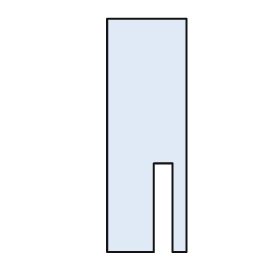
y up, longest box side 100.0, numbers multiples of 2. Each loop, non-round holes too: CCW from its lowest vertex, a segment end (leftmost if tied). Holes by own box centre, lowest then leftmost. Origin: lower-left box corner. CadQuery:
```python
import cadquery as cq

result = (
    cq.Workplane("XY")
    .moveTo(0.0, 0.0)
    .lineTo(20.0, 0.0)
    .lineTo(20.0, 38.0)
    .lineTo(28.0, 38.0)
    .lineTo(28.0, 0.0)
    .lineTo(34.0, 0.0)
    .lineTo(34.0, 100.0)
    .lineTo(0.0, 100.0)
    .close()
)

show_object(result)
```